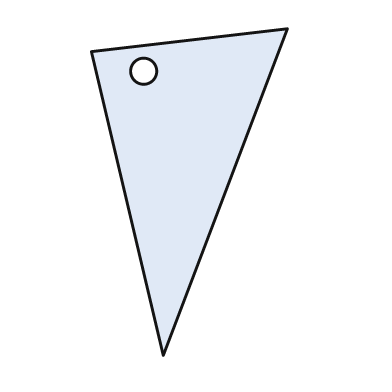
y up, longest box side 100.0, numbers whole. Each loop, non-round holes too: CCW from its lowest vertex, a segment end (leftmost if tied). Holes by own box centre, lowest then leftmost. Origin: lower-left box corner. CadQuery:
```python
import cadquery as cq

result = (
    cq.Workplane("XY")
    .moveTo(22.0, 0.0)
    .lineTo(60.0, 100.0)
    .lineTo(0.0, 93.0)
    .close()
    .moveTo(16.0, 87.0)
    .circle(4.0)
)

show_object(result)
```